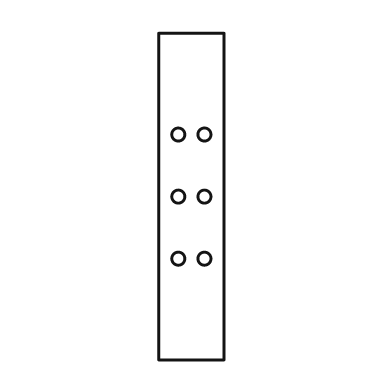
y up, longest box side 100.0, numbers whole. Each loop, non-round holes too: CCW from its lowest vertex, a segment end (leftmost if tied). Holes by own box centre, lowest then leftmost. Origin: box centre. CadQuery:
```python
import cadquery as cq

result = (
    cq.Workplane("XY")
    .moveTo(-10.0, -50.0)
    .lineTo(10.0, -50.0)
    .lineTo(10.0, 50.0)
    .lineTo(-10.0, 50.0)
    .close()
    .moveTo(-4.0, -19.0)
    .circle(2.0)
    .moveTo(4.0, -19.0)
    .circle(2.0)
    .moveTo(-4.0, 0.0)
    .circle(2.0)
    .moveTo(4.0, 0.0)
    .circle(2.0)
    .moveTo(-4.0, 19.0)
    .circle(2.0)
    .moveTo(4.0, 19.0)
    .circle(2.0)
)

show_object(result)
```